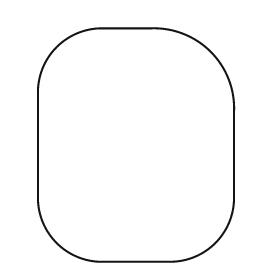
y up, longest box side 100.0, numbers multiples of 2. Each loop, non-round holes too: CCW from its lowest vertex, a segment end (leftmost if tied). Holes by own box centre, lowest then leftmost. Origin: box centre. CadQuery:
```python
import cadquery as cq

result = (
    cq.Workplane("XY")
    .moveTo(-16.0, -50.0)
    .lineTo(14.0, -50.0)
    .threePointArc((34.0, -42.0), (42.0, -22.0))
    .lineTo(42.0, 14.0)
    .threePointArc((32.0, 40.0), (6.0, 50.0))
    .lineTo(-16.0, 50.0)
    .threePointArc((-34.0, 42.0), (-42.0, 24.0))
    .lineTo(-42.0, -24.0)
    .threePointArc((-34.0, -42.0), (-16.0, -50.0))
    .close()
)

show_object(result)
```